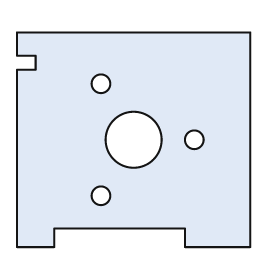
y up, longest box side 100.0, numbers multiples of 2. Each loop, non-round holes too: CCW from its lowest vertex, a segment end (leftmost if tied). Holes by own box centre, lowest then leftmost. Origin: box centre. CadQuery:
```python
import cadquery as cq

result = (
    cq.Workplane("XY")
    .moveTo(-50.0, -46.0)
    .lineTo(-34.0, -46.0)
    .lineTo(-34.0, -38.0)
    .lineTo(22.0, -38.0)
    .lineTo(22.0, -46.0)
    .lineTo(50.0, -46.0)
    .lineTo(50.0, 46.0)
    .lineTo(-50.0, 46.0)
    .lineTo(-50.0, 36.0)
    .lineTo(-42.0, 36.0)
    .lineTo(-42.0, 30.0)
    .lineTo(-50.0, 30.0)
    .close()
    .moveTo(-14.0, -24.0)
    .circle(4.0)
    .moveTo(0.0, 0.0)
    .circle(12.0)
    .moveTo(26.0, 0.0)
    .circle(4.0)
    .moveTo(-14.0, 24.0)
    .circle(4.0)
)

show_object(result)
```